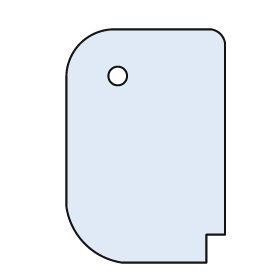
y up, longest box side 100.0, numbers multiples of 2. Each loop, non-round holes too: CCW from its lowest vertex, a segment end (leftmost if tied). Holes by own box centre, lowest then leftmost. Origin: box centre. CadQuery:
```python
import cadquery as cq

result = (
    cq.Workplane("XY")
    .moveTo(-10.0, -50.0)
    .lineTo(26.0, -50.0)
    .lineTo(26.0, -38.0)
    .lineTo(34.0, -38.0)
    .lineTo(34.0, 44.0)
    .threePointArc((32.0, 48.0), (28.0, 50.0))
    .lineTo(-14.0, 50.0)
    .threePointArc((-28.0, 44.0), (-34.0, 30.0))
    .lineTo(-34.0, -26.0)
    .threePointArc((-26.0, -42.0), (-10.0, -50.0))
    .close()
    .moveTo(-12.0, 30.0)
    .circle(4.0)
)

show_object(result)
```